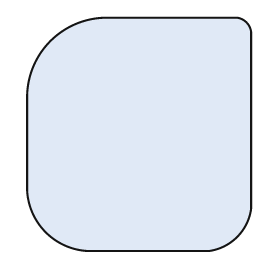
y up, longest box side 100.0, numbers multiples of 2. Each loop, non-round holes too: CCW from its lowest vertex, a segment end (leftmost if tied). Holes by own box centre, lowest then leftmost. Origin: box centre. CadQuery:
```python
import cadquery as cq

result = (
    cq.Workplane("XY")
    .moveTo(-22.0, -50.0)
    .lineTo(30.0, -50.0)
    .threePointArc((42.0, -44.0), (48.0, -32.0))
    .lineTo(48.0, 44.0)
    .threePointArc((46.0, 48.0), (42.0, 50.0))
    .lineTo(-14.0, 50.0)
    .threePointArc((-38.0, 40.0), (-48.0, 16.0))
    .lineTo(-48.0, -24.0)
    .threePointArc((-40.0, -42.0), (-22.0, -50.0))
    .close()
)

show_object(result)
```